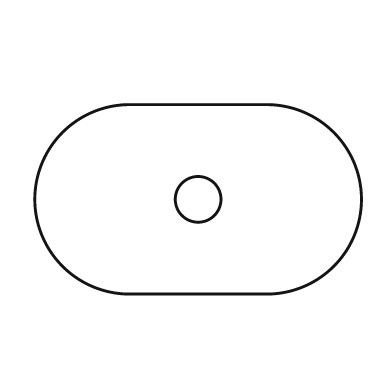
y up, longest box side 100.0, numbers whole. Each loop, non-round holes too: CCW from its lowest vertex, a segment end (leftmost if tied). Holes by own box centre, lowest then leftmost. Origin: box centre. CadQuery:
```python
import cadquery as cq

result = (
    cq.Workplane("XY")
    .moveTo(-21.0, -29.0)
    .lineTo(21.0, -29.0)
    .threePointArc((50.0, 0.0), (21.0, 29.0))
    .lineTo(-21.0, 29.0)
    .threePointArc((-50.0, 0.0), (-21.0, -29.0))
    .close()
    .moveTo(0.0, 0.0)
    .circle(7.0)
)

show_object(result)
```